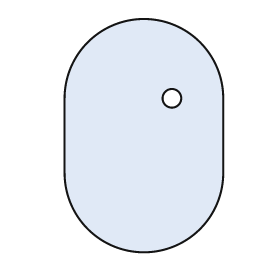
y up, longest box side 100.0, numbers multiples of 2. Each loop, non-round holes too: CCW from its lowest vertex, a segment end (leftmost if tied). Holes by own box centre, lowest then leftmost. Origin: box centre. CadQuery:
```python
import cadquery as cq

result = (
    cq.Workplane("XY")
    .moveTo(-34.0, -16.0)
    .threePointArc((0.0, -50.0), (34.0, -16.0))
    .lineTo(34.0, 16.0)
    .threePointArc((0.0, 50.0), (-34.0, 16.0))
    .close()
    .moveTo(12.0, 16.0)
    .circle(4.0)
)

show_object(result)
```